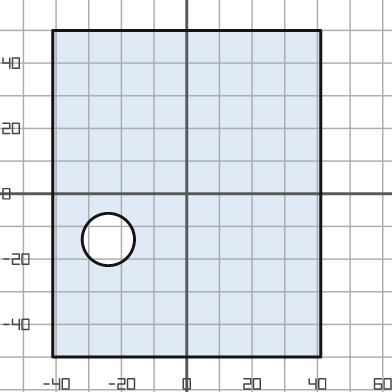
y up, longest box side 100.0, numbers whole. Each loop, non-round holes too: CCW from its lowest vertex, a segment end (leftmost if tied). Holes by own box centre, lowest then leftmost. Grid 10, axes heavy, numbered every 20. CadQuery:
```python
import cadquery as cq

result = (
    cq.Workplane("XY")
    .moveTo(-41.0, -50.0)
    .lineTo(41.0, -50.0)
    .lineTo(41.0, 50.0)
    .lineTo(-41.0, 50.0)
    .close()
    .moveTo(-24.0, -14.0)
    .circle(8.0)
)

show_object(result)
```